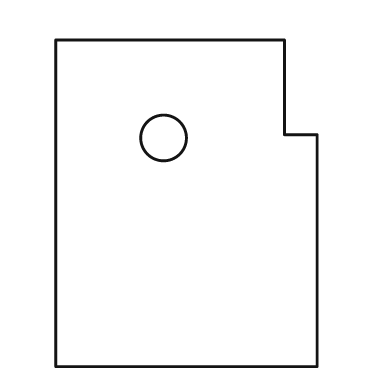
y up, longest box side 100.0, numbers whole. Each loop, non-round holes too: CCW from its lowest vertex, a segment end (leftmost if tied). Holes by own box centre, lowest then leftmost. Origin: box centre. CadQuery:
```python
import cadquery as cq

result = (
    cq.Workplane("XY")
    .moveTo(-40.0, -50.0)
    .lineTo(40.0, -50.0)
    .lineTo(40.0, 21.0)
    .lineTo(30.0, 21.0)
    .lineTo(30.0, 50.0)
    .lineTo(-40.0, 50.0)
    .close()
    .moveTo(-7.0, 20.0)
    .circle(7.0)
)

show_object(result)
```